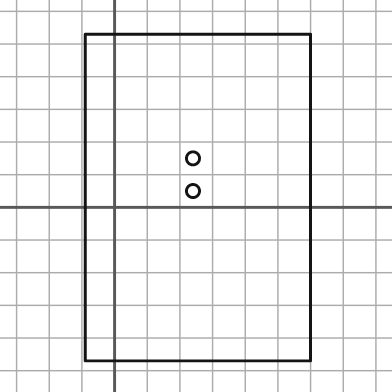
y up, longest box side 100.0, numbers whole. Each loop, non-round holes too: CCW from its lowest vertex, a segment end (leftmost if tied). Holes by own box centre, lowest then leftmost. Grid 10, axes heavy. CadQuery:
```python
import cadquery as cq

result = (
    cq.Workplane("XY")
    .moveTo(-9.0, -47.0)
    .lineTo(60.0, -47.0)
    .lineTo(60.0, 53.0)
    .lineTo(-9.0, 53.0)
    .close()
    .moveTo(24.0, 5.0)
    .circle(2.0)
    .moveTo(24.0, 15.0)
    .circle(2.0)
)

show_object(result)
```